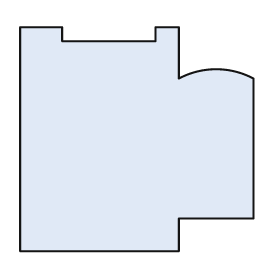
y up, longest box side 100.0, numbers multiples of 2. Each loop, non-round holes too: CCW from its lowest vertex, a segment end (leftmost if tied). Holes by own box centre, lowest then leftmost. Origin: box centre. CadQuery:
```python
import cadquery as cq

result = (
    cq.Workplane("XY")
    .moveTo(-50.0, -48.0)
    .lineTo(18.0, -48.0)
    .lineTo(18.0, -34.0)
    .lineTo(50.0, -34.0)
    .lineTo(50.0, 26.0)
    .threePointArc((34.0, 30.0), (18.0, 26.0))
    .lineTo(18.0, 48.0)
    .lineTo(8.0, 48.0)
    .lineTo(8.0, 42.0)
    .lineTo(-32.0, 42.0)
    .lineTo(-32.0, 48.0)
    .lineTo(-50.0, 48.0)
    .close()
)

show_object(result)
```